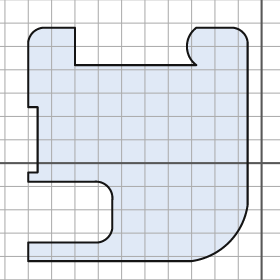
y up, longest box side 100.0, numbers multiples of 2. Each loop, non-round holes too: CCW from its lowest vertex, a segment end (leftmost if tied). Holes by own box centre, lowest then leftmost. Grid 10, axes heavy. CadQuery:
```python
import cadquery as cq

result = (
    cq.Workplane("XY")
    .moveTo(-100.0, -42.0)
    .lineTo(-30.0, -42.0)
    .threePointArc((-14.0, -34.0), (-6.0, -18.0))
    .lineTo(-6.0, 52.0)
    .threePointArc((-8.0, 56.0), (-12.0, 58.0))
    .lineTo(-28.0, 58.0)
    .threePointArc((-32.0, 50.0), (-28.0, 42.0))
    .lineTo(-80.0, 42.0)
    .lineTo(-80.0, 58.0)
    .lineTo(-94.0, 58.0)
    .threePointArc((-98.0, 56.0), (-100.0, 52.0))
    .lineTo(-100.0, 24.0)
    .lineTo(-96.0, 24.0)
    .lineTo(-96.0, -4.0)
    .lineTo(-100.0, -4.0)
    .lineTo(-100.0, -8.0)
    .lineTo(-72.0, -8.0)
    .threePointArc((-66.0, -10.0), (-64.0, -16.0))
    .lineTo(-64.0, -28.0)
    .threePointArc((-66.0, -32.0), (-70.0, -34.0))
    .lineTo(-100.0, -34.0)
    .close()
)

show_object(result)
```